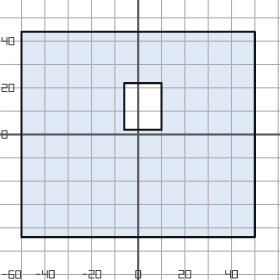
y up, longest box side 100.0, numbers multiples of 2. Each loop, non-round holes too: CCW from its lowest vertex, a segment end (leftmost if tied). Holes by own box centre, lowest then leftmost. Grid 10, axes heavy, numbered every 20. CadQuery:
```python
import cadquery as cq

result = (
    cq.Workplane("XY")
    .moveTo(-50.0, -44.0)
    .lineTo(50.0, -44.0)
    .lineTo(50.0, 44.0)
    .lineTo(-50.0, 44.0)
    .close()
    .moveTo(-6.0, 2.0)
    .lineTo(10.0, 2.0)
    .lineTo(10.0, 22.0)
    .lineTo(-6.0, 22.0)
    .close()
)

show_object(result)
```